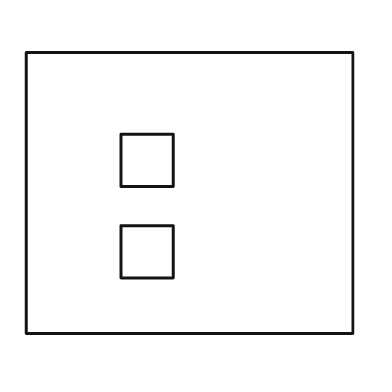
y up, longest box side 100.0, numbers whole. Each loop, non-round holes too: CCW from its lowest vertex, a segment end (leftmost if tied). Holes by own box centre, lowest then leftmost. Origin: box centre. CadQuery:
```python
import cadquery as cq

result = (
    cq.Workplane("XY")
    .moveTo(-50.0, -43.0)
    .lineTo(50.0, -43.0)
    .lineTo(50.0, 43.0)
    .lineTo(-50.0, 43.0)
    .close()
    .moveTo(-21.0, -26.0)
    .lineTo(-5.0, -26.0)
    .lineTo(-5.0, -10.0)
    .lineTo(-21.0, -10.0)
    .close()
    .moveTo(-21.0, 2.0)
    .lineTo(-5.0, 2.0)
    .lineTo(-5.0, 18.0)
    .lineTo(-21.0, 18.0)
    .close()
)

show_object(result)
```